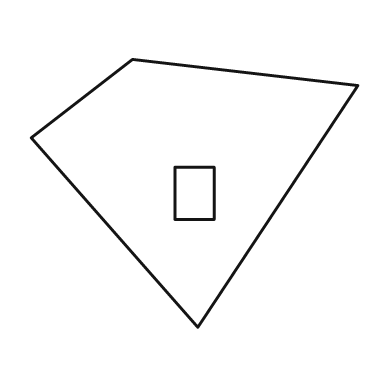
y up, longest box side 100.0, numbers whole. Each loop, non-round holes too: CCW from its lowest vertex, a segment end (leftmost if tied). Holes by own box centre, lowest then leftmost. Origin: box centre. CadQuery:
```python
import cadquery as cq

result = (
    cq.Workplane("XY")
    .moveTo(1.0, -41.0)
    .lineTo(50.0, 33.0)
    .lineTo(-19.0, 41.0)
    .lineTo(-50.0, 17.0)
    .close()
    .moveTo(-6.0, -8.0)
    .lineTo(6.0, -8.0)
    .lineTo(6.0, 8.0)
    .lineTo(-6.0, 8.0)
    .close()
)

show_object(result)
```